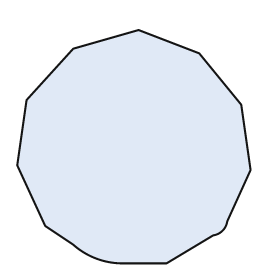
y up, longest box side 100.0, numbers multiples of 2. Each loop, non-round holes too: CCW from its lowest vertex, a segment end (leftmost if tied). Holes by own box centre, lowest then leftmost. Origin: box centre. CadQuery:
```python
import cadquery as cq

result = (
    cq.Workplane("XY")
    .moveTo(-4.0, -50.0)
    .lineTo(14.0, -50.0)
    .lineTo(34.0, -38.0)
    .threePointArc((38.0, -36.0), (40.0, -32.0))
    .lineTo(50.0, -10.0)
    .lineTo(46.0, 18.0)
    .lineTo(28.0, 40.0)
    .lineTo(2.0, 50.0)
    .lineTo(-26.0, 42.0)
    .lineTo(-46.0, 20.0)
    .lineTo(-50.0, -8.0)
    .lineTo(-38.0, -34.0)
    .lineTo(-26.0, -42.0)
    .threePointArc((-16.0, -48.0), (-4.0, -50.0))
    .close()
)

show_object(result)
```